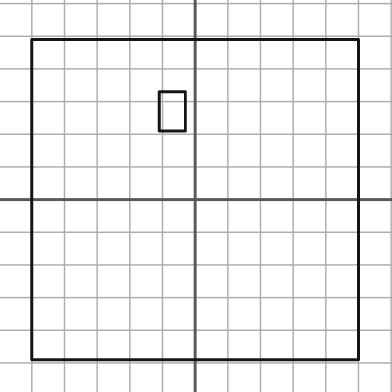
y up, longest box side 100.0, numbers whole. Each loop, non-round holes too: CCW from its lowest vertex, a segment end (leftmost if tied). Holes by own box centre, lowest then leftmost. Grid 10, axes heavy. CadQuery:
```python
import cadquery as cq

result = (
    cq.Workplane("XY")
    .moveTo(-50.0, -49.0)
    .lineTo(50.0, -49.0)
    .lineTo(50.0, 49.0)
    .lineTo(-50.0, 49.0)
    .close()
    .moveTo(-11.0, 21.0)
    .lineTo(-3.0, 21.0)
    .lineTo(-3.0, 33.0)
    .lineTo(-11.0, 33.0)
    .close()
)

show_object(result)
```